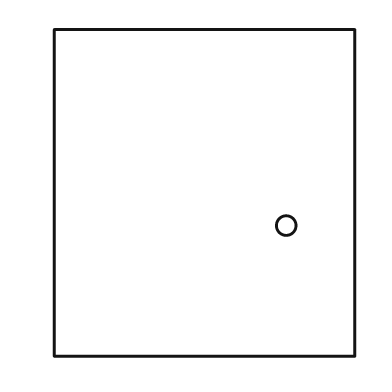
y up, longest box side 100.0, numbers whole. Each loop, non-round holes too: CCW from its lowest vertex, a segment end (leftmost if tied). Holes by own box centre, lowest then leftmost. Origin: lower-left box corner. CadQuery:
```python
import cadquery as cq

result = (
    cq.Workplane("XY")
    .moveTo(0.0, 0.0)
    .lineTo(92.0, 0.0)
    .lineTo(92.0, 100.0)
    .lineTo(0.0, 100.0)
    .close()
    .moveTo(71.0, 40.0)
    .circle(3.0)
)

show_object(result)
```